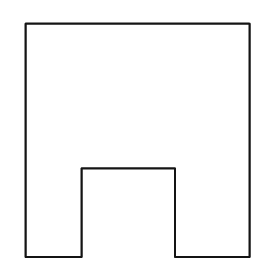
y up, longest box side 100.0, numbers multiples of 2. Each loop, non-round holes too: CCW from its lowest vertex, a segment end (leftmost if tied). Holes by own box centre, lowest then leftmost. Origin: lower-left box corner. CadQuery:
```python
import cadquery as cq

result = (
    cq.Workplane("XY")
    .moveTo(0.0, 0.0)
    .lineTo(24.0, 0.0)
    .lineTo(24.0, 38.0)
    .lineTo(64.0, 38.0)
    .lineTo(64.0, 0.0)
    .lineTo(96.0, 0.0)
    .lineTo(96.0, 100.0)
    .lineTo(0.0, 100.0)
    .close()
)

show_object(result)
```